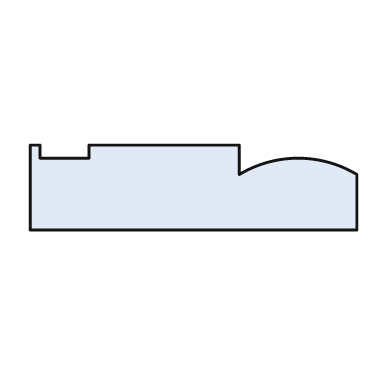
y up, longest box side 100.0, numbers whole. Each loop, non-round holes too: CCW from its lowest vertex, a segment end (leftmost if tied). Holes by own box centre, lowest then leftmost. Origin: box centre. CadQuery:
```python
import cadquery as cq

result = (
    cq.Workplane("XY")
    .moveTo(-50.0, -13.0)
    .lineTo(50.0, -13.0)
    .lineTo(50.0, 4.0)
    .threePointArc((32.0, 9.0), (14.0, 4.0))
    .lineTo(14.0, 13.0)
    .lineTo(-32.0, 13.0)
    .lineTo(-32.0, 9.0)
    .lineTo(-47.0, 9.0)
    .lineTo(-47.0, 13.0)
    .lineTo(-50.0, 13.0)
    .close()
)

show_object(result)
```